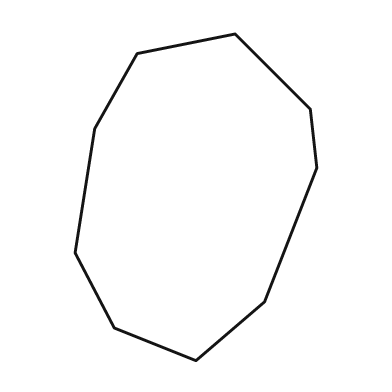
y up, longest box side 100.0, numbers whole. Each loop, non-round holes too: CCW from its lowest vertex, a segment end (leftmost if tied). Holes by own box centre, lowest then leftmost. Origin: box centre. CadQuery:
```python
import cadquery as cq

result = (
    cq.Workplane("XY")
    .moveTo(0.0, -50.0)
    .lineTo(21.0, -32.0)
    .lineTo(37.0, 9.0)
    .lineTo(35.0, 27.0)
    .lineTo(12.0, 50.0)
    .lineTo(-18.0, 44.0)
    .lineTo(-31.0, 21.0)
    .lineTo(-37.0, -17.0)
    .lineTo(-25.0, -40.0)
    .close()
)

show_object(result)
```